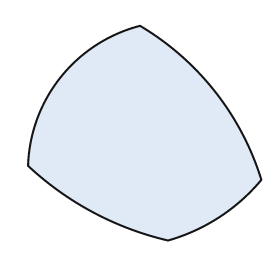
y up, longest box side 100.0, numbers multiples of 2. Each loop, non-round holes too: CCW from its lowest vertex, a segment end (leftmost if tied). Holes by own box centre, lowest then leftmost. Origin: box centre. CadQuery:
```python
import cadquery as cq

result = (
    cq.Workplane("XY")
    .moveTo(10.0, -46.0)
    .threePointArc((32.0, -36.0), (50.0, -20.0))
    .threePointArc((30.0, 18.0), (-2.0, 46.0))
    .threePointArc((-36.0, 24.0), (-50.0, -14.0))
    .threePointArc((-22.0, -34.0), (10.0, -46.0))
    .close()
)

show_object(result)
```